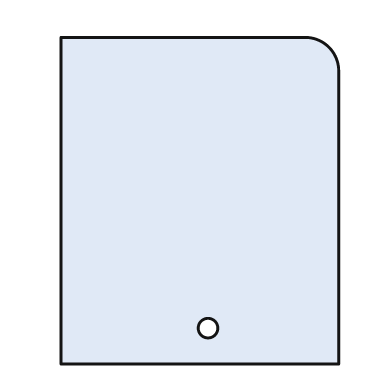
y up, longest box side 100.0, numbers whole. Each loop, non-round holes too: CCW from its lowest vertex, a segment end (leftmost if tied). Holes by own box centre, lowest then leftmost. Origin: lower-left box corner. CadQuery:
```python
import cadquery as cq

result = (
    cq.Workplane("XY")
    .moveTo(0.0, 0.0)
    .lineTo(85.0, 0.0)
    .lineTo(85.0, 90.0)
    .threePointArc((82.0, 97.0), (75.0, 100.0))
    .lineTo(0.0, 100.0)
    .close()
    .moveTo(45.0, 11.0)
    .circle(3.0)
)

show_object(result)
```